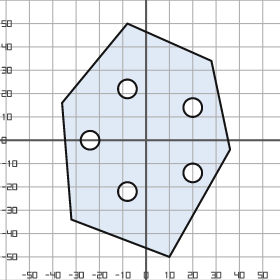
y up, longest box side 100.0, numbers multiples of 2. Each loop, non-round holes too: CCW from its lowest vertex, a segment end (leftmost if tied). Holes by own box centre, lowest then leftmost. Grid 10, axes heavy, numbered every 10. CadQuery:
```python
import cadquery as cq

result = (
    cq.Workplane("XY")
    .moveTo(10.0, -50.0)
    .lineTo(36.0, -4.0)
    .lineTo(28.0, 34.0)
    .lineTo(-8.0, 50.0)
    .lineTo(-36.0, 16.0)
    .lineTo(-32.0, -34.0)
    .close()
    .moveTo(-8.0, -22.0)
    .circle(4.0)
    .moveTo(20.0, -14.0)
    .circle(4.0)
    .moveTo(-24.0, 0.0)
    .circle(4.0)
    .moveTo(20.0, 14.0)
    .circle(4.0)
    .moveTo(-8.0, 22.0)
    .circle(4.0)
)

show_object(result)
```